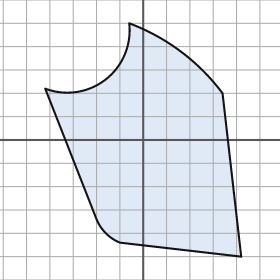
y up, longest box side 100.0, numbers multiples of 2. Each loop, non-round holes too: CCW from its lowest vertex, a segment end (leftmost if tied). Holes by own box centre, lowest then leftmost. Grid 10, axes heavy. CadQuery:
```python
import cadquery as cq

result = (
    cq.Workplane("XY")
    .moveTo(42.0, -50.0)
    .lineTo(34.0, 20.0)
    .threePointArc((16.0, 38.0), (-6.0, 50.0))
    .threePointArc((-16.0, 26.0), (-42.0, 22.0))
    .lineTo(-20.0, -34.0)
    .threePointArc((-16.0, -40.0), (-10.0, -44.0))
    .close()
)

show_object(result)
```